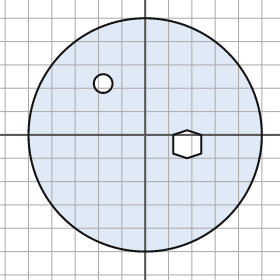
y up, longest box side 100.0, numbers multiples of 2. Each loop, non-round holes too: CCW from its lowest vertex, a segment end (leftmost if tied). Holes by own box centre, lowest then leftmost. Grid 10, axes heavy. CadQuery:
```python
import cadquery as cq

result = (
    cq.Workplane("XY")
    .moveTo(0.0, 0.0)
    .circle(50.0)
    .moveTo(18.0, -10.0)
    .lineTo(24.0, -8.0)
    .lineTo(24.0, 0.0)
    .lineTo(18.0, 2.0)
    .lineTo(12.0, 0.0)
    .lineTo(12.0, -8.0)
    .close()
    .moveTo(-18.0, 22.0)
    .circle(4.0)
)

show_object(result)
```